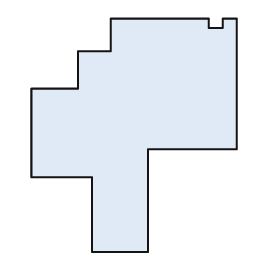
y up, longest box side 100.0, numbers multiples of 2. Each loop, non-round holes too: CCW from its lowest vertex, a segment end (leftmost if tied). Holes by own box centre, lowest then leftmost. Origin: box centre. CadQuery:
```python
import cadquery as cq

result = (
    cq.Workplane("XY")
    .moveTo(-18.0, -50.0)
    .lineTo(6.0, -50.0)
    .lineTo(6.0, -6.0)
    .lineTo(44.0, -6.0)
    .lineTo(44.0, 50.0)
    .lineTo(38.0, 50.0)
    .lineTo(38.0, 46.0)
    .lineTo(32.0, 46.0)
    .lineTo(32.0, 50.0)
    .lineTo(-10.0, 50.0)
    .lineTo(-10.0, 36.0)
    .lineTo(-24.0, 36.0)
    .lineTo(-24.0, 20.0)
    .lineTo(-44.0, 20.0)
    .lineTo(-44.0, -18.0)
    .lineTo(-18.0, -18.0)
    .close()
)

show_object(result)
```